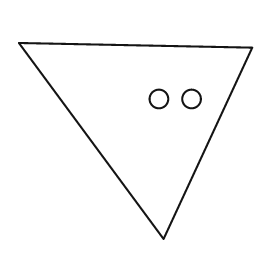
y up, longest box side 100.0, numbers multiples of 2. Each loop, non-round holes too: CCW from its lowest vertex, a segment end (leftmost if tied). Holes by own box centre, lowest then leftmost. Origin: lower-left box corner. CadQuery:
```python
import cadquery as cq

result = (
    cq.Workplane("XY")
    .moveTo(62.0, 0.0)
    .lineTo(100.0, 82.0)
    .lineTo(0.0, 84.0)
    .close()
    .moveTo(60.0, 60.0)
    .circle(4.0)
    .moveTo(74.0, 60.0)
    .circle(4.0)
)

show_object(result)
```